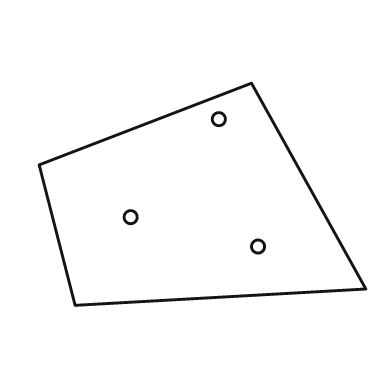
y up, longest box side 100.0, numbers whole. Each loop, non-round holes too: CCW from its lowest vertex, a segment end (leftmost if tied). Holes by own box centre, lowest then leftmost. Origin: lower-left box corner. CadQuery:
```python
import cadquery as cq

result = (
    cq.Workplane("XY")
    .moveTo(11.0, 0.0)
    .lineTo(100.0, 5.0)
    .lineTo(65.0, 68.0)
    .lineTo(0.0, 43.0)
    .close()
    .moveTo(67.0, 18.0)
    .circle(2.0)
    .moveTo(28.0, 27.0)
    .circle(2.0)
    .moveTo(55.0, 57.0)
    .circle(2.0)
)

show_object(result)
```